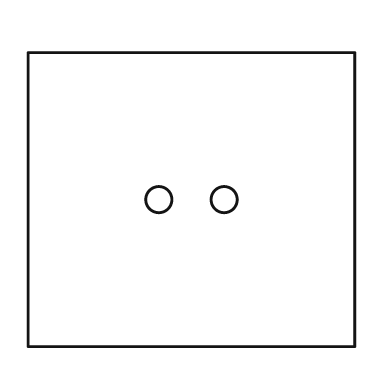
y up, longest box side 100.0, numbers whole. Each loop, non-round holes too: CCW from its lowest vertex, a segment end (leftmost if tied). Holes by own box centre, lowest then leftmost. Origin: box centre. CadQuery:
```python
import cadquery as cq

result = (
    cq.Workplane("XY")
    .moveTo(-50.0, -45.0)
    .lineTo(50.0, -45.0)
    .lineTo(50.0, 45.0)
    .lineTo(-50.0, 45.0)
    .close()
    .moveTo(-10.0, 0.0)
    .circle(4.0)
    .moveTo(10.0, 0.0)
    .circle(4.0)
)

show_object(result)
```